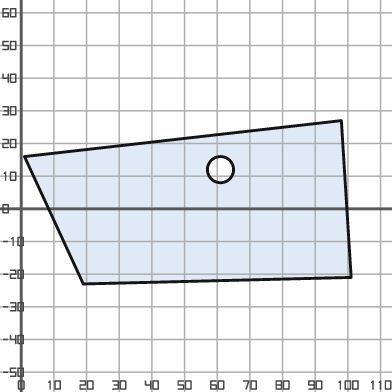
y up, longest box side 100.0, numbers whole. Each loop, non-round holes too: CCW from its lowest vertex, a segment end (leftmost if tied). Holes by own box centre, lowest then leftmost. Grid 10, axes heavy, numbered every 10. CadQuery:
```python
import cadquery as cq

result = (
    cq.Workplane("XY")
    .moveTo(19.0, -23.0)
    .lineTo(101.0, -21.0)
    .lineTo(98.0, 27.0)
    .lineTo(1.0, 16.0)
    .close()
    .moveTo(61.0, 12.0)
    .circle(4.0)
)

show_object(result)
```